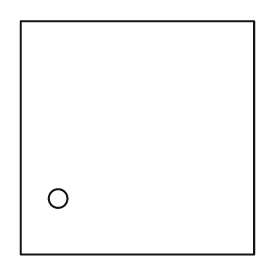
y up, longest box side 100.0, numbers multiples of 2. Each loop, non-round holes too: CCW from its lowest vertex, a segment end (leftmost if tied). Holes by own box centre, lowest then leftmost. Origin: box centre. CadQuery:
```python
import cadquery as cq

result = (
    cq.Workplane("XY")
    .moveTo(-50.0, -50.0)
    .lineTo(50.0, -50.0)
    .lineTo(50.0, 50.0)
    .lineTo(-50.0, 50.0)
    .close()
    .moveTo(-34.0, -26.0)
    .circle(4.0)
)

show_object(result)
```